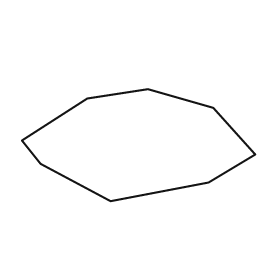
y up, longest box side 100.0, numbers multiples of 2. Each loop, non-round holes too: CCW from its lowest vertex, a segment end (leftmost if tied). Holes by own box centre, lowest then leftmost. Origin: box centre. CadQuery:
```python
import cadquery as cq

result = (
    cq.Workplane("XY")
    .moveTo(-12.0, -24.0)
    .lineTo(30.0, -16.0)
    .lineTo(50.0, -4.0)
    .lineTo(32.0, 16.0)
    .lineTo(4.0, 24.0)
    .lineTo(-22.0, 20.0)
    .lineTo(-50.0, 2.0)
    .lineTo(-42.0, -8.0)
    .close()
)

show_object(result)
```